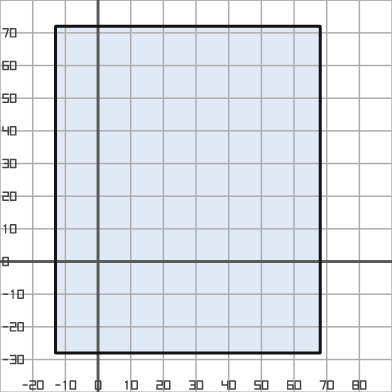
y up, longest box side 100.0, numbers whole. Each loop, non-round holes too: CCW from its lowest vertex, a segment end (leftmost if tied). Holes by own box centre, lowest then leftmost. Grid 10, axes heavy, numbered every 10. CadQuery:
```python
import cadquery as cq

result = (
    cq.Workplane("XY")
    .moveTo(-13.0, -28.0)
    .lineTo(68.0, -28.0)
    .lineTo(68.0, 72.0)
    .lineTo(-13.0, 72.0)
    .close()
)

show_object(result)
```